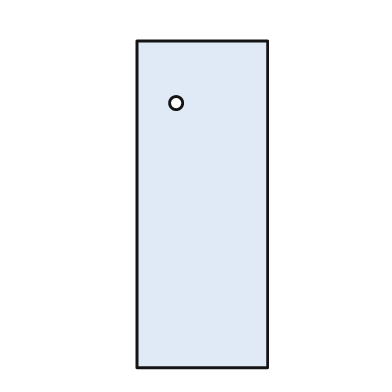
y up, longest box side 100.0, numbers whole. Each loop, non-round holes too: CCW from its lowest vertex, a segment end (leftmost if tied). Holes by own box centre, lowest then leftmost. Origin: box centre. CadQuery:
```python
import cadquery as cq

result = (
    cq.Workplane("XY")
    .moveTo(-20.0, -50.0)
    .lineTo(20.0, -50.0)
    .lineTo(20.0, 50.0)
    .lineTo(-20.0, 50.0)
    .close()
    .moveTo(-8.0, 31.0)
    .circle(2.0)
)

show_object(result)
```